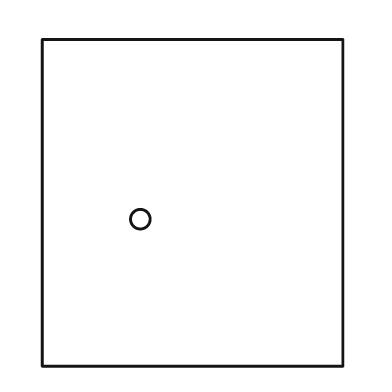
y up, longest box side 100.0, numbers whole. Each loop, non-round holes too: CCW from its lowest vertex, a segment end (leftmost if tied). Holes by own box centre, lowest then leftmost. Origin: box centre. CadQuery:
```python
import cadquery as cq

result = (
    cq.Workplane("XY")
    .moveTo(-46.0, -50.0)
    .lineTo(46.0, -50.0)
    .lineTo(46.0, 50.0)
    .lineTo(-46.0, 50.0)
    .close()
    .moveTo(-16.0, -5.0)
    .circle(3.0)
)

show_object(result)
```